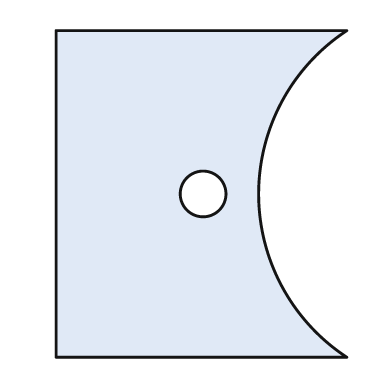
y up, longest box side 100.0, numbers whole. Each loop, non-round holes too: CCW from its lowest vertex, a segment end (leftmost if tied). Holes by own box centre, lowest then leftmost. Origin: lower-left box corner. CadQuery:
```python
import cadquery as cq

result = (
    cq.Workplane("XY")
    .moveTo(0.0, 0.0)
    .lineTo(89.0, 0.0)
    .threePointArc((62.0, 50.0), (89.0, 100.0))
    .lineTo(0.0, 100.0)
    .close()
    .moveTo(45.0, 50.0)
    .circle(7.0)
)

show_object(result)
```